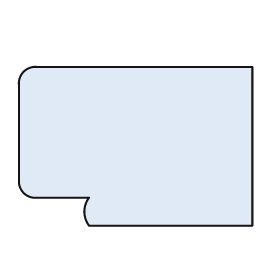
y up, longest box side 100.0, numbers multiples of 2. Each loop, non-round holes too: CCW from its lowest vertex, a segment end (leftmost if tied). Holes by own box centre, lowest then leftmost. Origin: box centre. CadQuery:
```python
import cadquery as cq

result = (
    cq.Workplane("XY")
    .moveTo(-20.0, -34.0)
    .lineTo(50.0, -34.0)
    .lineTo(50.0, 34.0)
    .lineTo(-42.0, 34.0)
    .threePointArc((-48.0, 32.0), (-50.0, 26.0))
    .lineTo(-50.0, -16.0)
    .threePointArc((-48.0, -20.0), (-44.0, -22.0))
    .lineTo(-20.0, -22.0)
    .threePointArc((-22.0, -28.0), (-20.0, -34.0))
    .close()
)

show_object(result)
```